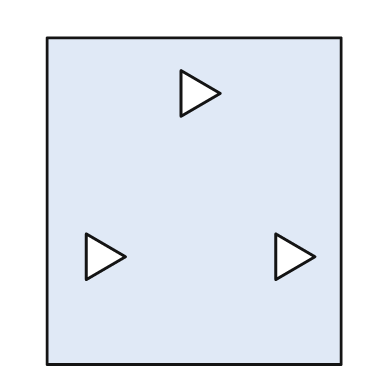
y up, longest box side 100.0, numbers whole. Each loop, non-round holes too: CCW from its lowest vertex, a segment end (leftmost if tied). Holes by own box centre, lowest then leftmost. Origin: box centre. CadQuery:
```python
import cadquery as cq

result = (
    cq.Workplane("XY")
    .moveTo(-45.0, -50.0)
    .lineTo(45.0, -50.0)
    .lineTo(45.0, 50.0)
    .lineTo(-45.0, 50.0)
    .close()
    .moveTo(-33.0, -24.0)
    .lineTo(-21.0, -17.0)
    .lineTo(-33.0, -10.0)
    .close()
    .moveTo(25.0, -24.0)
    .lineTo(37.0, -17.0)
    .lineTo(25.0, -10.0)
    .close()
    .moveTo(-4.0, 26.0)
    .lineTo(8.0, 33.0)
    .lineTo(-4.0, 40.0)
    .close()
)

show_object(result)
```